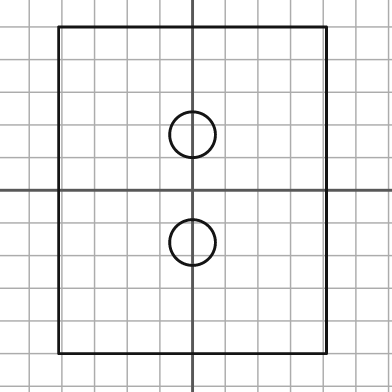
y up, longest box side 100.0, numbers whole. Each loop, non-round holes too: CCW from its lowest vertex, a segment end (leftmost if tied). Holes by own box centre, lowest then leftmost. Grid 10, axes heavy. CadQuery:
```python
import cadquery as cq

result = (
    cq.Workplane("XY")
    .moveTo(-41.0, -50.0)
    .lineTo(41.0, -50.0)
    .lineTo(41.0, 50.0)
    .lineTo(-41.0, 50.0)
    .close()
    .moveTo(0.0, -16.0)
    .circle(7.0)
    .moveTo(0.0, 17.0)
    .circle(7.0)
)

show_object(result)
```